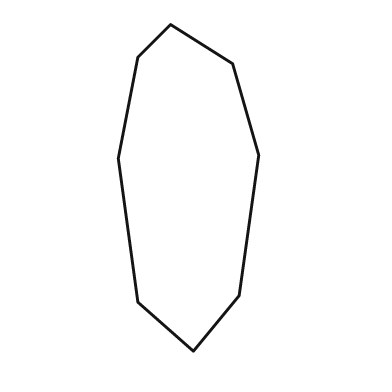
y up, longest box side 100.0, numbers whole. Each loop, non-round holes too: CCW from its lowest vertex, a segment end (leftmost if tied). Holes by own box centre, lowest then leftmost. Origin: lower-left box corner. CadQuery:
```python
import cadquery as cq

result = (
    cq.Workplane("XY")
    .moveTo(23.0, 0.0)
    .lineTo(37.0, 17.0)
    .lineTo(43.0, 60.0)
    .lineTo(35.0, 88.0)
    .lineTo(16.0, 100.0)
    .lineTo(6.0, 90.0)
    .lineTo(0.0, 59.0)
    .lineTo(6.0, 15.0)
    .close()
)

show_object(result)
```